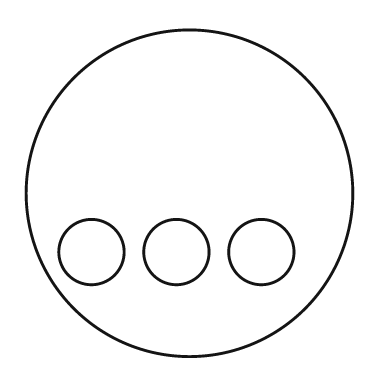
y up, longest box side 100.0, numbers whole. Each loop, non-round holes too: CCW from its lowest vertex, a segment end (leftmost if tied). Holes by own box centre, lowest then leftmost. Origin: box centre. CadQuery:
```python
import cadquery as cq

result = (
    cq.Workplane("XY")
    .moveTo(0.0, 0.0)
    .circle(50.0)
    .moveTo(-30.0, -18.0)
    .circle(10.0)
    .moveTo(-4.0, -18.0)
    .circle(10.0)
    .moveTo(22.0, -18.0)
    .circle(10.0)
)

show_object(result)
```